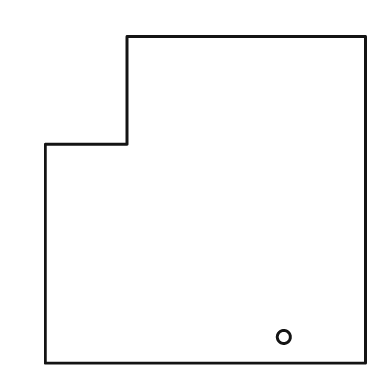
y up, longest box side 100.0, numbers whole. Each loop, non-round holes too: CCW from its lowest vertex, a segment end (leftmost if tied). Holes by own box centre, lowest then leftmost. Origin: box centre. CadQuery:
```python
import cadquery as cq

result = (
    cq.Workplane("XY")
    .moveTo(-49.0, -50.0)
    .lineTo(49.0, -50.0)
    .lineTo(49.0, 50.0)
    .lineTo(-24.0, 50.0)
    .lineTo(-24.0, 17.0)
    .lineTo(-49.0, 17.0)
    .close()
    .moveTo(24.0, -42.0)
    .circle(2.0)
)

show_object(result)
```